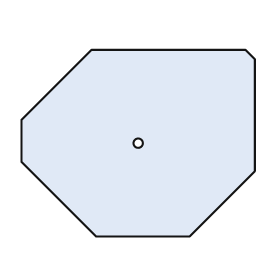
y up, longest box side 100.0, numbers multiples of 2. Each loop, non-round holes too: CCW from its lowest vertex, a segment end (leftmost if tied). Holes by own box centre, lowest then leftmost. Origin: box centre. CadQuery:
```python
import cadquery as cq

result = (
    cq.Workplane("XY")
    .moveTo(-18.0, -40.0)
    .lineTo(22.0, -40.0)
    .lineTo(50.0, -12.0)
    .lineTo(50.0, 36.0)
    .lineTo(46.0, 40.0)
    .lineTo(-20.0, 40.0)
    .lineTo(-50.0, 10.0)
    .lineTo(-50.0, -8.0)
    .close()
    .moveTo(0.0, 0.0)
    .circle(2.0)
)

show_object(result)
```